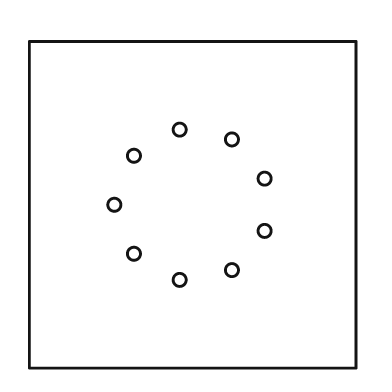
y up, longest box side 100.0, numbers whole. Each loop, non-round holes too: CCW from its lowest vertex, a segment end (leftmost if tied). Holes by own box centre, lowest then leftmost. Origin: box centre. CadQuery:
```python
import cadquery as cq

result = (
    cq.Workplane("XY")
    .moveTo(-50.0, -50.0)
    .lineTo(50.0, -50.0)
    .lineTo(50.0, 50.0)
    .lineTo(-50.0, 50.0)
    .close()
    .moveTo(-4.0, -23.0)
    .circle(2.0)
    .moveTo(12.0, -20.0)
    .circle(2.0)
    .moveTo(-18.0, -15.0)
    .circle(2.0)
    .moveTo(22.0, -8.0)
    .circle(2.0)
    .moveTo(-24.0, 0.0)
    .circle(2.0)
    .moveTo(22.0, 8.0)
    .circle(2.0)
    .moveTo(-18.0, 15.0)
    .circle(2.0)
    .moveTo(12.0, 20.0)
    .circle(2.0)
    .moveTo(-4.0, 23.0)
    .circle(2.0)
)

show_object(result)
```